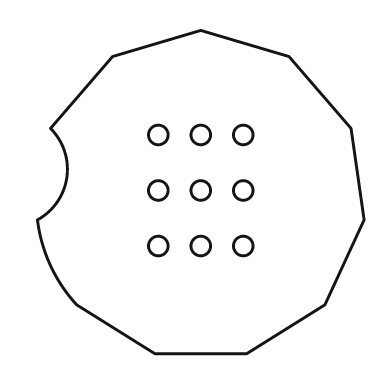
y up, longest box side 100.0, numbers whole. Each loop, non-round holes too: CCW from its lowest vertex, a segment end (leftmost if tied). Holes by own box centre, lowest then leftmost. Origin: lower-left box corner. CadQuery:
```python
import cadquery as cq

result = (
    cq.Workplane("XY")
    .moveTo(36.0, 0.0)
    .lineTo(64.0, 0.0)
    .lineTo(88.0, 15.0)
    .lineTo(100.0, 41.0)
    .lineTo(96.0, 69.0)
    .lineTo(77.0, 91.0)
    .lineTo(50.0, 99.0)
    .lineTo(23.0, 91.0)
    .lineTo(4.0, 69.0)
    .threePointArc((9.0, 54.0), (0.0, 41.0))
    .threePointArc((4.0, 27.0), (12.0, 15.0))
    .close()
    .moveTo(37.0, 33.0)
    .circle(3.0)
    .moveTo(50.0, 33.0)
    .circle(3.0)
    .moveTo(63.0, 33.0)
    .circle(3.0)
    .moveTo(37.0, 50.0)
    .circle(3.0)
    .moveTo(50.0, 50.0)
    .circle(3.0)
    .moveTo(63.0, 50.0)
    .circle(3.0)
    .moveTo(37.0, 67.0)
    .circle(3.0)
    .moveTo(50.0, 67.0)
    .circle(3.0)
    .moveTo(63.0, 67.0)
    .circle(3.0)
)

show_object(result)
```